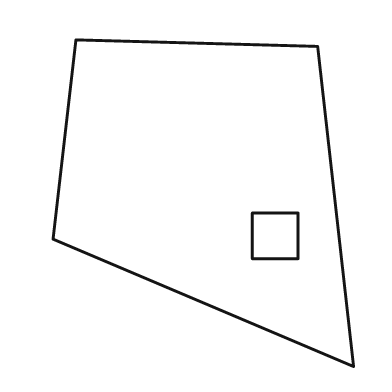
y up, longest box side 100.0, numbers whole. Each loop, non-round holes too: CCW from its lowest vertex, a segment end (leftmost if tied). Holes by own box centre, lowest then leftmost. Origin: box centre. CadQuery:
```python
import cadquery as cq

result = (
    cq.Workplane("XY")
    .moveTo(46.0, -50.0)
    .lineTo(35.0, 48.0)
    .lineTo(-39.0, 50.0)
    .lineTo(-46.0, -11.0)
    .close()
    .moveTo(15.0, -17.0)
    .lineTo(29.0, -17.0)
    .lineTo(29.0, -3.0)
    .lineTo(15.0, -3.0)
    .close()
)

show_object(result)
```